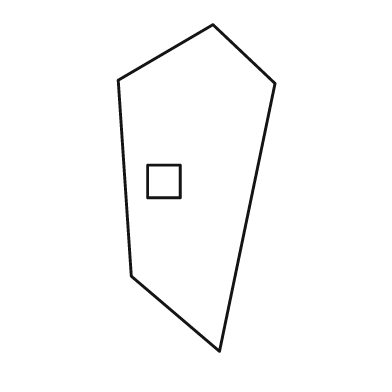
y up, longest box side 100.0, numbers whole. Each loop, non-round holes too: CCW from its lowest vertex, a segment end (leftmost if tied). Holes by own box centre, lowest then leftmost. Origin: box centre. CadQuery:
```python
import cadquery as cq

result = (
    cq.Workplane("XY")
    .moveTo(7.0, -50.0)
    .lineTo(24.0, 32.0)
    .lineTo(5.0, 50.0)
    .lineTo(-24.0, 33.0)
    .lineTo(-20.0, -27.0)
    .close()
    .moveTo(-15.0, -3.0)
    .lineTo(-5.0, -3.0)
    .lineTo(-5.0, 7.0)
    .lineTo(-15.0, 7.0)
    .close()
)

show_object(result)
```